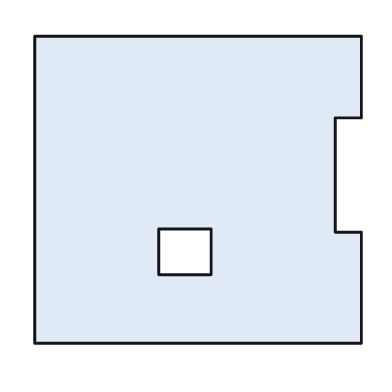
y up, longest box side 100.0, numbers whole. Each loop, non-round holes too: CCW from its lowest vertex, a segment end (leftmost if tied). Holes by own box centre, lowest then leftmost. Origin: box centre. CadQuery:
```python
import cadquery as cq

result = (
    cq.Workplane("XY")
    .moveTo(-50.0, -47.0)
    .lineTo(50.0, -47.0)
    .lineTo(50.0, -13.0)
    .lineTo(42.0, -13.0)
    .lineTo(42.0, 22.0)
    .lineTo(50.0, 22.0)
    .lineTo(50.0, 47.0)
    .lineTo(-50.0, 47.0)
    .close()
    .moveTo(-12.0, -26.0)
    .lineTo(4.0, -26.0)
    .lineTo(4.0, -12.0)
    .lineTo(-12.0, -12.0)
    .close()
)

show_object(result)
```